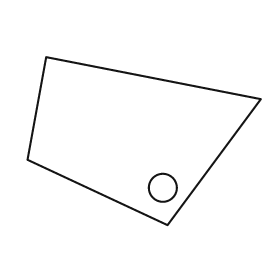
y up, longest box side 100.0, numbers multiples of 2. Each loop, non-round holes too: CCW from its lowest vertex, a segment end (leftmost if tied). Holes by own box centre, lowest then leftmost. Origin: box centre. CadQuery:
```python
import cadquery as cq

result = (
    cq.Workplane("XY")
    .moveTo(10.0, -36.0)
    .lineTo(50.0, 18.0)
    .lineTo(-42.0, 36.0)
    .lineTo(-50.0, -8.0)
    .close()
    .moveTo(8.0, -20.0)
    .circle(6.0)
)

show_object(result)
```